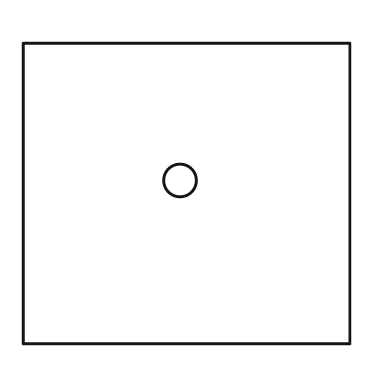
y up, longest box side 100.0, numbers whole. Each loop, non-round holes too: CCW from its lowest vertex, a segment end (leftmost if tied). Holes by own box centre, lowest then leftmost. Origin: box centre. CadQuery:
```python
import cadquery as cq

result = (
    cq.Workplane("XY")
    .moveTo(-50.0, -46.0)
    .lineTo(50.0, -46.0)
    .lineTo(50.0, 46.0)
    .lineTo(-50.0, 46.0)
    .close()
    .moveTo(-2.0, 4.0)
    .circle(5.0)
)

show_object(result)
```